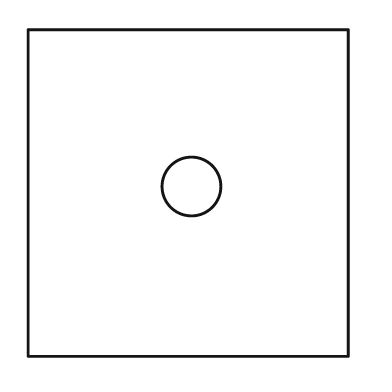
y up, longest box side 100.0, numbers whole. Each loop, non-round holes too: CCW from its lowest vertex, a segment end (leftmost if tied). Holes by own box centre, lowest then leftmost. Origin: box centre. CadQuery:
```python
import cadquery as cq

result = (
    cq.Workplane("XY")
    .moveTo(-49.0, -50.0)
    .lineTo(49.0, -50.0)
    .lineTo(49.0, 50.0)
    .lineTo(-49.0, 50.0)
    .close()
    .moveTo(1.0, 2.0)
    .circle(9.0)
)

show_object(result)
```